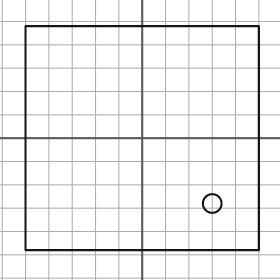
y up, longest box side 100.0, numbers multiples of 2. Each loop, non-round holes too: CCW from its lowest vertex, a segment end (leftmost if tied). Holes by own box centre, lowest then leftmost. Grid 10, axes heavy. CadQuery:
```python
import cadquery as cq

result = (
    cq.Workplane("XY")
    .moveTo(-50.0, -48.0)
    .lineTo(50.0, -48.0)
    .lineTo(50.0, 48.0)
    .lineTo(-50.0, 48.0)
    .close()
    .moveTo(30.0, -28.0)
    .circle(4.0)
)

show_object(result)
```